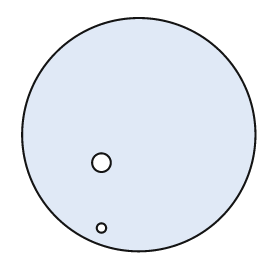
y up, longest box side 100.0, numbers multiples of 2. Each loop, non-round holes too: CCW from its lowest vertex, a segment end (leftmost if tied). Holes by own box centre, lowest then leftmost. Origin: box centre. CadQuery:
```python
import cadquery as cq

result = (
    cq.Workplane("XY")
    .moveTo(0.0, 0.0)
    .circle(50.0)
    .moveTo(-16.0, -40.0)
    .circle(2.0)
    .moveTo(-16.0, -12.0)
    .circle(4.0)
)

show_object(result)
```